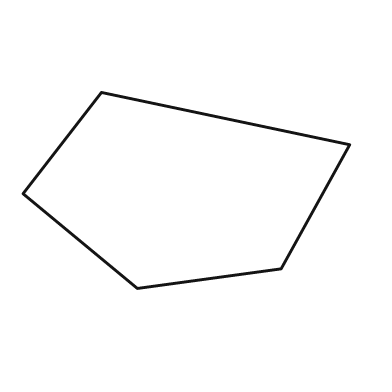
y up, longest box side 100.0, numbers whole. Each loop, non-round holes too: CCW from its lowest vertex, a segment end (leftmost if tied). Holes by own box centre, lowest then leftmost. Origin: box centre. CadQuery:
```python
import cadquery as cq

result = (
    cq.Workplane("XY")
    .moveTo(-15.0, -30.0)
    .lineTo(29.0, -24.0)
    .lineTo(50.0, 14.0)
    .lineTo(-26.0, 30.0)
    .lineTo(-50.0, -1.0)
    .close()
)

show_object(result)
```